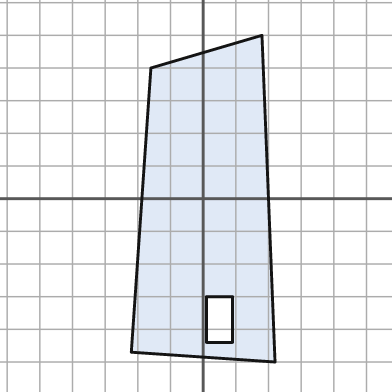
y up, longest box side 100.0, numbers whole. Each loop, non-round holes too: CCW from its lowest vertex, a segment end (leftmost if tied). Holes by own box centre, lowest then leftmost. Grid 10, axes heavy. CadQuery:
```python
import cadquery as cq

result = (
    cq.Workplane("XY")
    .moveTo(22.0, -50.0)
    .lineTo(18.0, 50.0)
    .lineTo(-16.0, 40.0)
    .lineTo(-22.0, -47.0)
    .close()
    .moveTo(1.0, -44.0)
    .lineTo(9.0, -44.0)
    .lineTo(9.0, -30.0)
    .lineTo(1.0, -30.0)
    .close()
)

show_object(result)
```